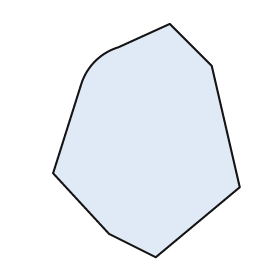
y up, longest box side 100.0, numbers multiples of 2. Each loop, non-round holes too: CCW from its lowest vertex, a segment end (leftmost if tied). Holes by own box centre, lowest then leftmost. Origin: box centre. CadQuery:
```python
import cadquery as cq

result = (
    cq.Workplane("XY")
    .moveTo(4.0, -50.0)
    .lineTo(40.0, -20.0)
    .lineTo(28.0, 32.0)
    .lineTo(10.0, 50.0)
    .lineTo(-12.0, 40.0)
    .threePointArc((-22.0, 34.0), (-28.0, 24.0))
    .lineTo(-40.0, -14.0)
    .lineTo(-16.0, -40.0)
    .close()
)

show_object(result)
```